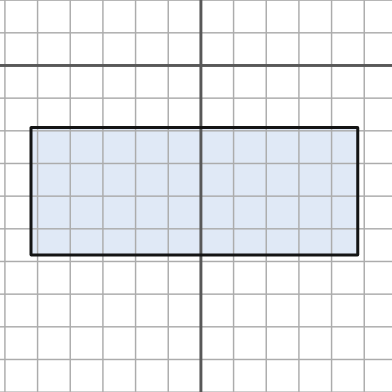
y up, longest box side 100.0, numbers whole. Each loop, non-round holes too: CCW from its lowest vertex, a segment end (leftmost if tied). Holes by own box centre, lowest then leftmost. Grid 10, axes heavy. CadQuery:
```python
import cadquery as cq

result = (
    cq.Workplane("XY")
    .moveTo(-52.0, -58.0)
    .lineTo(48.0, -58.0)
    .lineTo(48.0, -19.0)
    .lineTo(-52.0, -19.0)
    .close()
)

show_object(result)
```